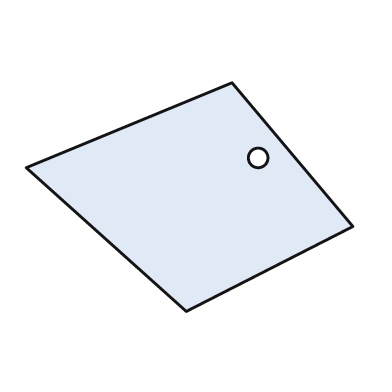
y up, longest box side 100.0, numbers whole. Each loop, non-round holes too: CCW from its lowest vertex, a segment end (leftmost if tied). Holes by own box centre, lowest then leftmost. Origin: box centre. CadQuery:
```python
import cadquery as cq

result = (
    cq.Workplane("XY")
    .moveTo(-1.0, -35.0)
    .lineTo(50.0, -9.0)
    .lineTo(13.0, 35.0)
    .lineTo(-50.0, 9.0)
    .close()
    .moveTo(21.0, 12.0)
    .circle(3.0)
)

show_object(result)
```